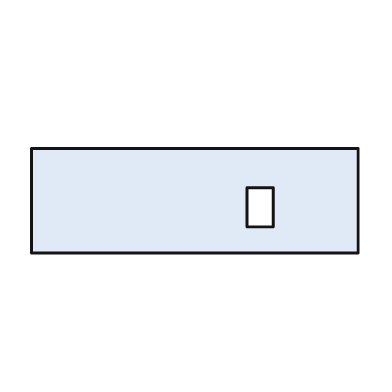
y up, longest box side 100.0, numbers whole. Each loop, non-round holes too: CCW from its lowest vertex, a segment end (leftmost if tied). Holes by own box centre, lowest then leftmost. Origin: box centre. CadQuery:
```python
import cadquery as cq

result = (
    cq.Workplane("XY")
    .moveTo(-50.0, -16.0)
    .lineTo(50.0, -16.0)
    .lineTo(50.0, 16.0)
    .lineTo(-50.0, 16.0)
    .close()
    .moveTo(16.0, -8.0)
    .lineTo(24.0, -8.0)
    .lineTo(24.0, 4.0)
    .lineTo(16.0, 4.0)
    .close()
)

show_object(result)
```